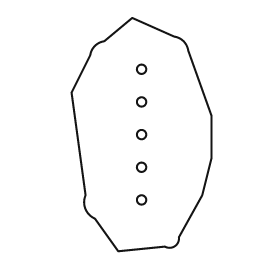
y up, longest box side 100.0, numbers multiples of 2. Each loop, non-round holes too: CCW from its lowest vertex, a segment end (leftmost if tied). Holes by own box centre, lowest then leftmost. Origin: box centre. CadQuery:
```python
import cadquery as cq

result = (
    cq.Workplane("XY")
    .moveTo(-10.0, -50.0)
    .lineTo(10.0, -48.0)
    .threePointArc((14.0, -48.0), (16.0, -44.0))
    .lineTo(26.0, -26.0)
    .lineTo(30.0, -10.0)
    .lineTo(30.0, 8.0)
    .lineTo(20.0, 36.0)
    .threePointArc((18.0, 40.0), (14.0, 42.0))
    .lineTo(-4.0, 50.0)
    .lineTo(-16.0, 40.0)
    .threePointArc((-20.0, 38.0), (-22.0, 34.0))
    .lineTo(-30.0, 18.0)
    .lineTo(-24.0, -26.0)
    .threePointArc((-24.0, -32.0), (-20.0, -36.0))
    .close()
    .moveTo(0.0, -28.0)
    .circle(2.0)
    .moveTo(0.0, -14.0)
    .circle(2.0)
    .moveTo(0.0, 0.0)
    .circle(2.0)
    .moveTo(0.0, 14.0)
    .circle(2.0)
    .moveTo(0.0, 28.0)
    .circle(2.0)
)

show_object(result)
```